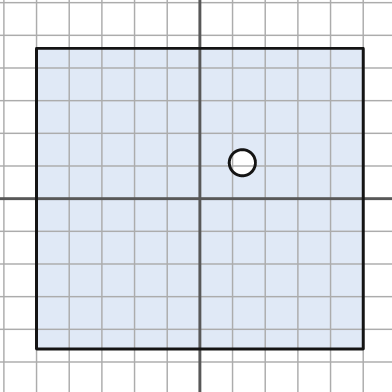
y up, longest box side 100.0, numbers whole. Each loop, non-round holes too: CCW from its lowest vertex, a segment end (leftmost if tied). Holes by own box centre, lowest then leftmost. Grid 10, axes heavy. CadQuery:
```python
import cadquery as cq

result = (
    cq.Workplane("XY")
    .moveTo(-50.0, -46.0)
    .lineTo(50.0, -46.0)
    .lineTo(50.0, 46.0)
    .lineTo(-50.0, 46.0)
    .close()
    .moveTo(13.0, 11.0)
    .circle(4.0)
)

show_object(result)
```